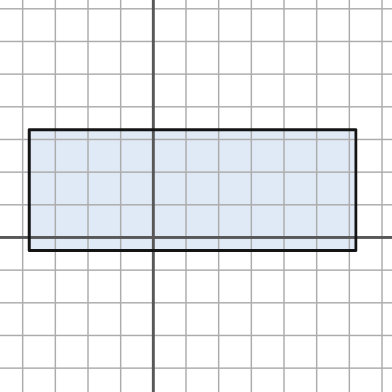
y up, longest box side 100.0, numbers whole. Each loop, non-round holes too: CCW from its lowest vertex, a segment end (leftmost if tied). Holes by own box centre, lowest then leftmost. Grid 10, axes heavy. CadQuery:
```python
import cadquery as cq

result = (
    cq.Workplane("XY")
    .moveTo(-38.0, -4.0)
    .lineTo(62.0, -4.0)
    .lineTo(62.0, 33.0)
    .lineTo(-38.0, 33.0)
    .close()
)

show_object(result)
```